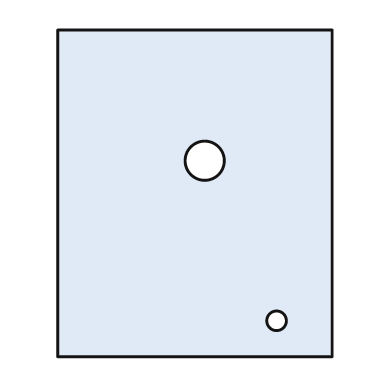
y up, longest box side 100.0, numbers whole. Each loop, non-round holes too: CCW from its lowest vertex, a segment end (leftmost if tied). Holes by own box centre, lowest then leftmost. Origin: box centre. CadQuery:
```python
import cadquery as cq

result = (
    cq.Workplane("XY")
    .moveTo(-42.0, -50.0)
    .lineTo(42.0, -50.0)
    .lineTo(42.0, 50.0)
    .lineTo(-42.0, 50.0)
    .close()
    .moveTo(25.0, -39.0)
    .circle(3.0)
    .moveTo(3.0, 10.0)
    .circle(6.0)
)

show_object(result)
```